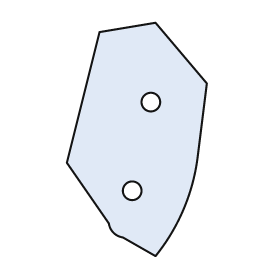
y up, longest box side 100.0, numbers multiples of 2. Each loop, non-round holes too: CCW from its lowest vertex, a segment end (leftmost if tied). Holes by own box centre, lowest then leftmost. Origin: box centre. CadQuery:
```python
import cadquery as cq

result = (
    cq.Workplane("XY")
    .moveTo(8.0, -50.0)
    .threePointArc((20.0, -30.0), (26.0, -8.0))
    .lineTo(30.0, 24.0)
    .lineTo(8.0, 50.0)
    .lineTo(-16.0, 46.0)
    .lineTo(-30.0, -10.0)
    .lineTo(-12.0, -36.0)
    .threePointArc((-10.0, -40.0), (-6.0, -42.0))
    .close()
    .moveTo(-2.0, -22.0)
    .circle(4.0)
    .moveTo(6.0, 16.0)
    .circle(4.0)
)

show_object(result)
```